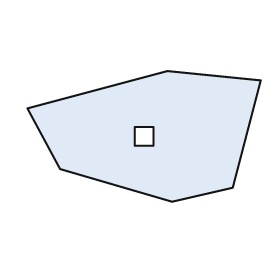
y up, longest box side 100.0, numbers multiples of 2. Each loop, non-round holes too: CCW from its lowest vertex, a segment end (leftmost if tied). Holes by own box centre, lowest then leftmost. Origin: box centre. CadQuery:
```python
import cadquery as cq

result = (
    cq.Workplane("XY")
    .moveTo(12.0, -28.0)
    .lineTo(38.0, -22.0)
    .lineTo(50.0, 24.0)
    .lineTo(10.0, 28.0)
    .lineTo(-50.0, 12.0)
    .lineTo(-36.0, -14.0)
    .close()
    .moveTo(-4.0, -4.0)
    .lineTo(4.0, -4.0)
    .lineTo(4.0, 4.0)
    .lineTo(-4.0, 4.0)
    .close()
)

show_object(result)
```